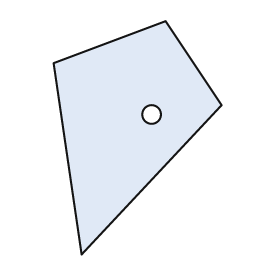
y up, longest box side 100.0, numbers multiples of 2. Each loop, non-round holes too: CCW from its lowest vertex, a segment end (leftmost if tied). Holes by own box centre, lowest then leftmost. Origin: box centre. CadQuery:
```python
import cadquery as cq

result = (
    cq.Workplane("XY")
    .moveTo(-24.0, -50.0)
    .lineTo(36.0, 14.0)
    .lineTo(12.0, 50.0)
    .lineTo(-36.0, 32.0)
    .close()
    .moveTo(6.0, 10.0)
    .circle(4.0)
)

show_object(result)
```